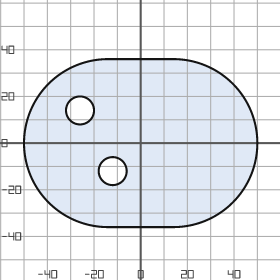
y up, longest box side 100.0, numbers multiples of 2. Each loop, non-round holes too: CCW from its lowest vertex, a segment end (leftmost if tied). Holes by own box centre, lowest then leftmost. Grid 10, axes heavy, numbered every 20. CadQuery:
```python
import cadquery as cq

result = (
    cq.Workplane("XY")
    .moveTo(-14.0, -36.0)
    .lineTo(14.0, -36.0)
    .threePointArc((50.0, 0.0), (14.0, 36.0))
    .lineTo(-14.0, 36.0)
    .threePointArc((-50.0, 0.0), (-14.0, -36.0))
    .close()
    .moveTo(-12.0, -12.0)
    .circle(6.0)
    .moveTo(-26.0, 14.0)
    .circle(6.0)
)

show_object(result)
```